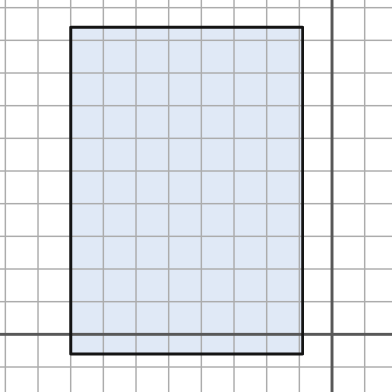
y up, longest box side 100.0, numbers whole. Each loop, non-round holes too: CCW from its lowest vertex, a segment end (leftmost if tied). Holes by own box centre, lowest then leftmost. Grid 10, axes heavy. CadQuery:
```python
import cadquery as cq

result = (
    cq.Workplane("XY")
    .moveTo(-80.0, -6.0)
    .lineTo(-9.0, -6.0)
    .lineTo(-9.0, 94.0)
    .lineTo(-80.0, 94.0)
    .close()
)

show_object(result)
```